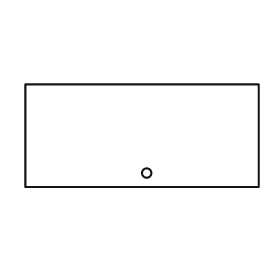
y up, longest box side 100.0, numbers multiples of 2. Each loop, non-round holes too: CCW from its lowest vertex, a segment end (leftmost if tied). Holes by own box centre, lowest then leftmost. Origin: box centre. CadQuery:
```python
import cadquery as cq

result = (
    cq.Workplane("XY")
    .moveTo(-50.0, -22.0)
    .lineTo(50.0, -22.0)
    .lineTo(50.0, 22.0)
    .lineTo(-50.0, 22.0)
    .close()
    .moveTo(2.0, -16.0)
    .circle(2.0)
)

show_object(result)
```